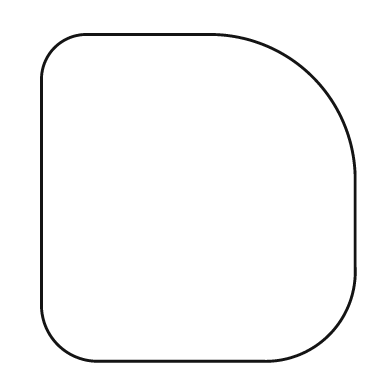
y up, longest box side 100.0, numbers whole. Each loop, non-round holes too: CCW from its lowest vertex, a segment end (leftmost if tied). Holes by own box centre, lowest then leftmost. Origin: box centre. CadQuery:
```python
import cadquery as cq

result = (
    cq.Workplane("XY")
    .moveTo(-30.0, -50.0)
    .lineTo(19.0, -50.0)
    .threePointArc((40.0, -42.0), (48.0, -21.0))
    .lineTo(48.0, 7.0)
    .threePointArc((35.0, 37.0), (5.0, 50.0))
    .lineTo(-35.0, 50.0)
    .threePointArc((-44.0, 46.0), (-48.0, 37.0))
    .lineTo(-48.0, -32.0)
    .threePointArc((-43.0, -45.0), (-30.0, -50.0))
    .close()
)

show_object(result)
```